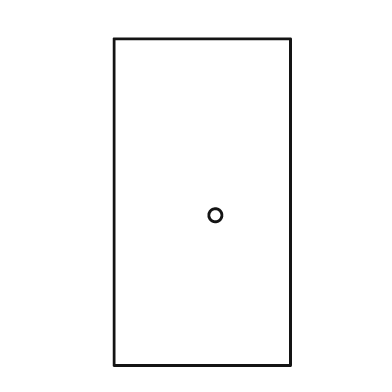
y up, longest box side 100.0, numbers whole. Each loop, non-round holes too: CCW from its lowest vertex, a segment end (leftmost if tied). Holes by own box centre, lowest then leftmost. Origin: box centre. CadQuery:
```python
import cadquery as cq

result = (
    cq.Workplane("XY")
    .moveTo(-27.0, -50.0)
    .lineTo(27.0, -50.0)
    .lineTo(27.0, 50.0)
    .lineTo(-27.0, 50.0)
    .close()
    .moveTo(4.0, -4.0)
    .circle(2.0)
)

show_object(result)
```